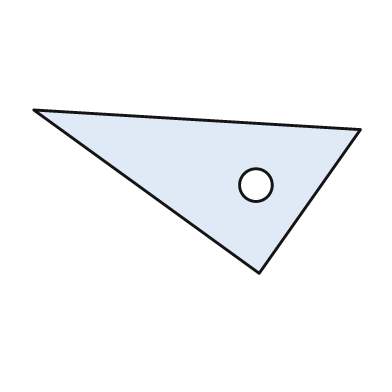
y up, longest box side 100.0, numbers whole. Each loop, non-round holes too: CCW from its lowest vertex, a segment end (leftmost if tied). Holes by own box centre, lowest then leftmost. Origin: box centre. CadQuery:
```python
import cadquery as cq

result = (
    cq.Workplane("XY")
    .moveTo(19.0, -25.0)
    .lineTo(50.0, 19.0)
    .lineTo(-50.0, 25.0)
    .close()
    .moveTo(18.0, 2.0)
    .circle(5.0)
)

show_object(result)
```